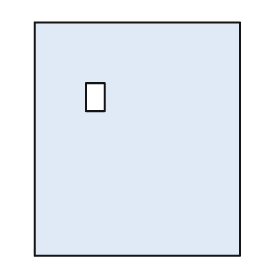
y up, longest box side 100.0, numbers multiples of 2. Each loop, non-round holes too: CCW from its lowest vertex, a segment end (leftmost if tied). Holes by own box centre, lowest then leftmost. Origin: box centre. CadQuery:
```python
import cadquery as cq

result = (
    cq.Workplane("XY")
    .moveTo(-44.0, -50.0)
    .lineTo(44.0, -50.0)
    .lineTo(44.0, 50.0)
    .lineTo(-44.0, 50.0)
    .close()
    .moveTo(-22.0, 12.0)
    .lineTo(-14.0, 12.0)
    .lineTo(-14.0, 24.0)
    .lineTo(-22.0, 24.0)
    .close()
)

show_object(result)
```